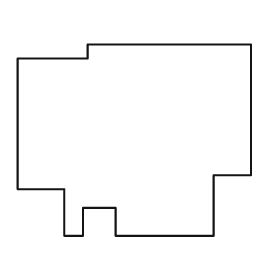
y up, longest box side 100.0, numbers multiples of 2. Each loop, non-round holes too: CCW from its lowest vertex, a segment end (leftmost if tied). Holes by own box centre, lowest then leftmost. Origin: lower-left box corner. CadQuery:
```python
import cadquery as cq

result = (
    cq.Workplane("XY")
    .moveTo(20.0, 0.0)
    .lineTo(28.0, 0.0)
    .lineTo(28.0, 12.0)
    .lineTo(42.0, 12.0)
    .lineTo(42.0, 0.0)
    .lineTo(84.0, 0.0)
    .lineTo(84.0, 26.0)
    .lineTo(100.0, 26.0)
    .lineTo(100.0, 82.0)
    .lineTo(30.0, 82.0)
    .lineTo(30.0, 76.0)
    .lineTo(0.0, 76.0)
    .lineTo(0.0, 20.0)
    .lineTo(20.0, 20.0)
    .close()
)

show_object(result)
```